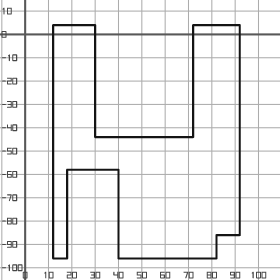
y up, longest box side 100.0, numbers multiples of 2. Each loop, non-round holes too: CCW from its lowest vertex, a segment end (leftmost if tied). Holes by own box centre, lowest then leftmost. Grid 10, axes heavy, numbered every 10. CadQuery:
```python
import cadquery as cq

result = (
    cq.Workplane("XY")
    .moveTo(12.0, -96.0)
    .lineTo(18.0, -96.0)
    .lineTo(18.0, -58.0)
    .lineTo(40.0, -58.0)
    .lineTo(40.0, -96.0)
    .lineTo(82.0, -96.0)
    .lineTo(82.0, -86.0)
    .lineTo(92.0, -86.0)
    .lineTo(92.0, 4.0)
    .lineTo(72.0, 4.0)
    .lineTo(72.0, -44.0)
    .lineTo(30.0, -44.0)
    .lineTo(30.0, 4.0)
    .lineTo(12.0, 4.0)
    .close()
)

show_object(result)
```